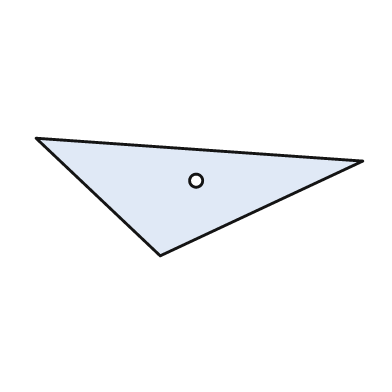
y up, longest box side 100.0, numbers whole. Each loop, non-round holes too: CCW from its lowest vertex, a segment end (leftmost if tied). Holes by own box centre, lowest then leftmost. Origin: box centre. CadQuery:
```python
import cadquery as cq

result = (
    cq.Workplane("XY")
    .moveTo(-12.0, -18.0)
    .lineTo(50.0, 11.0)
    .lineTo(-50.0, 18.0)
    .close()
    .moveTo(-1.0, 5.0)
    .circle(2.0)
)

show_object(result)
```